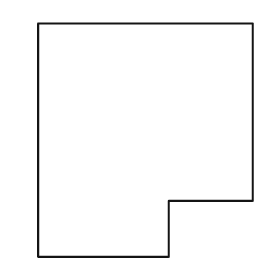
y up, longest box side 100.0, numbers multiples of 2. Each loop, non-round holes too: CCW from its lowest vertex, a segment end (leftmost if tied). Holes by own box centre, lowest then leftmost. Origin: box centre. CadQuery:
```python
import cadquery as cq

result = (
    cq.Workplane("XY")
    .moveTo(-46.0, -50.0)
    .lineTo(10.0, -50.0)
    .lineTo(10.0, -26.0)
    .lineTo(46.0, -26.0)
    .lineTo(46.0, 50.0)
    .lineTo(-46.0, 50.0)
    .close()
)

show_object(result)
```